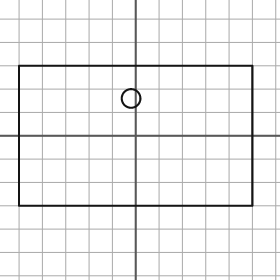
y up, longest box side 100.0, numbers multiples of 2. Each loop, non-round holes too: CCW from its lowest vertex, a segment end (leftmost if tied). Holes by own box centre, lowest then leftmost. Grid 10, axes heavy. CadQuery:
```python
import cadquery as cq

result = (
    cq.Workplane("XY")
    .moveTo(-50.0, -30.0)
    .lineTo(50.0, -30.0)
    .lineTo(50.0, 30.0)
    .lineTo(-50.0, 30.0)
    .close()
    .moveTo(-2.0, 16.0)
    .circle(4.0)
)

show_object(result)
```